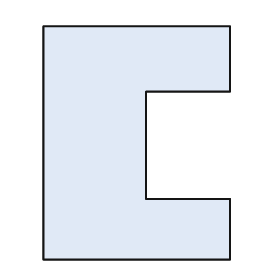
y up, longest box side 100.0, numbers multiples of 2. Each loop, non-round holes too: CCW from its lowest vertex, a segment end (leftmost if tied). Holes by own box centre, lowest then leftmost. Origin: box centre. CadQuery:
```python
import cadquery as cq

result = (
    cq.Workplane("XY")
    .moveTo(-40.0, -50.0)
    .lineTo(40.0, -50.0)
    .lineTo(40.0, -24.0)
    .lineTo(4.0, -24.0)
    .lineTo(4.0, 22.0)
    .lineTo(40.0, 22.0)
    .lineTo(40.0, 50.0)
    .lineTo(-40.0, 50.0)
    .close()
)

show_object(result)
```